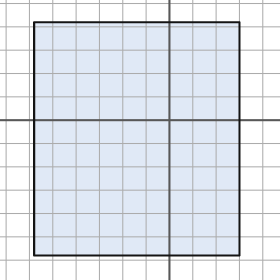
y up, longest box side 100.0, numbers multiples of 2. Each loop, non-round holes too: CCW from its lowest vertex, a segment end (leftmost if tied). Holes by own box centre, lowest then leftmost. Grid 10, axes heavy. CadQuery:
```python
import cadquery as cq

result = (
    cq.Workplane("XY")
    .moveTo(-58.0, -58.0)
    .lineTo(30.0, -58.0)
    .lineTo(30.0, 42.0)
    .lineTo(-58.0, 42.0)
    .close()
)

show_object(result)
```